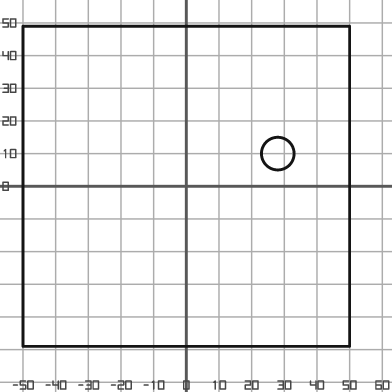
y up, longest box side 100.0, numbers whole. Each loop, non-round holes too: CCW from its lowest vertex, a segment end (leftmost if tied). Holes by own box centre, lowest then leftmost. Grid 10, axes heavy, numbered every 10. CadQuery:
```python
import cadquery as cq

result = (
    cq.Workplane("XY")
    .moveTo(-50.0, -49.0)
    .lineTo(50.0, -49.0)
    .lineTo(50.0, 49.0)
    .lineTo(-50.0, 49.0)
    .close()
    .moveTo(28.0, 10.0)
    .circle(5.0)
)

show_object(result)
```